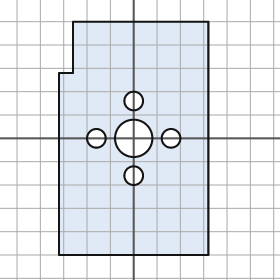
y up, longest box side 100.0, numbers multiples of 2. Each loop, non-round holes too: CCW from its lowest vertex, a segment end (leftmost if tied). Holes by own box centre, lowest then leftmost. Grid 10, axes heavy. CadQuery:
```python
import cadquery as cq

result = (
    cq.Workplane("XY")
    .moveTo(-32.0, -50.0)
    .lineTo(32.0, -50.0)
    .lineTo(32.0, 50.0)
    .lineTo(-26.0, 50.0)
    .lineTo(-26.0, 28.0)
    .lineTo(-32.0, 28.0)
    .close()
    .moveTo(0.0, -16.0)
    .circle(4.0)
    .moveTo(-16.0, 0.0)
    .circle(4.0)
    .moveTo(0.0, 0.0)
    .circle(8.0)
    .moveTo(16.0, 0.0)
    .circle(4.0)
    .moveTo(0.0, 16.0)
    .circle(4.0)
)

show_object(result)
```